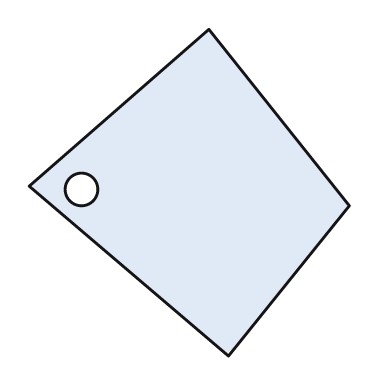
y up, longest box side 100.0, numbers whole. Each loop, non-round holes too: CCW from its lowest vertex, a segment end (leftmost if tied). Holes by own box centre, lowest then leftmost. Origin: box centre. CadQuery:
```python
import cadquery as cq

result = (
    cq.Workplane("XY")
    .moveTo(12.0, -50.0)
    .lineTo(49.0, -4.0)
    .lineTo(6.0, 50.0)
    .lineTo(-49.0, 2.0)
    .close()
    .moveTo(-33.0, 1.0)
    .circle(5.0)
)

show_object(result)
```